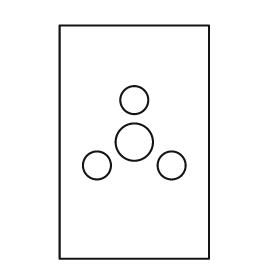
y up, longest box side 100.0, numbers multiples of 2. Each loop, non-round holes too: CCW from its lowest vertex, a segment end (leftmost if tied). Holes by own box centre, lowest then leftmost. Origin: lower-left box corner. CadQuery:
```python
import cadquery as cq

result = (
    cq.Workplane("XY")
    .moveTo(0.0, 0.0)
    .lineTo(64.0, 0.0)
    .lineTo(64.0, 100.0)
    .lineTo(0.0, 100.0)
    .close()
    .moveTo(16.0, 40.0)
    .circle(6.0)
    .moveTo(48.0, 40.0)
    .circle(6.0)
    .moveTo(32.0, 50.0)
    .circle(8.0)
    .moveTo(32.0, 68.0)
    .circle(6.0)
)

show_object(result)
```